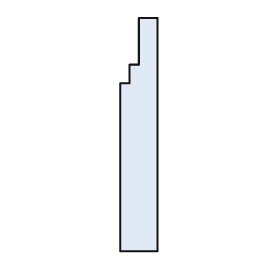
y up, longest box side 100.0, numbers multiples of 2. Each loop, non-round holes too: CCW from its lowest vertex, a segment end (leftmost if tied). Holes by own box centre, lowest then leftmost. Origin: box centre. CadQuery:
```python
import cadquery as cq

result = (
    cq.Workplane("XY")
    .moveTo(-8.0, -50.0)
    .lineTo(8.0, -50.0)
    .lineTo(8.0, 50.0)
    .lineTo(0.0, 50.0)
    .lineTo(0.0, 30.0)
    .lineTo(-4.0, 30.0)
    .lineTo(-4.0, 22.0)
    .lineTo(-8.0, 22.0)
    .close()
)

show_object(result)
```